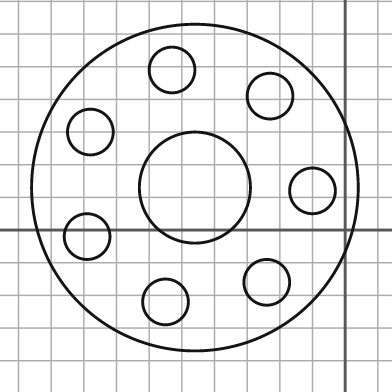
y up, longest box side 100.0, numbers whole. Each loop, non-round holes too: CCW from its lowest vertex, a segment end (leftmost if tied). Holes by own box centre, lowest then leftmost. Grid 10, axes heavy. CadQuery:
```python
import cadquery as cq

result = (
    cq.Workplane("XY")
    .moveTo(-46.0, 13.0)
    .circle(50.0)
    .moveTo(-55.0, -22.0)
    .circle(7.0)
    .moveTo(-24.0, -16.0)
    .circle(7.0)
    .moveTo(-79.0, -2.0)
    .circle(7.0)
    .moveTo(-10.0, 12.0)
    .circle(7.0)
    .moveTo(-46.0, 13.0)
    .circle(17.0)
    .moveTo(-78.0, 30.0)
    .circle(7.0)
    .moveTo(-23.0, 41.0)
    .circle(7.0)
    .moveTo(-53.0, 49.0)
    .circle(7.0)
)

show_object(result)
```